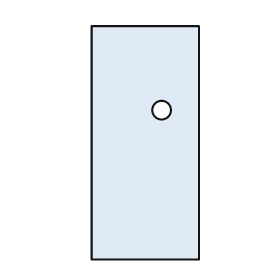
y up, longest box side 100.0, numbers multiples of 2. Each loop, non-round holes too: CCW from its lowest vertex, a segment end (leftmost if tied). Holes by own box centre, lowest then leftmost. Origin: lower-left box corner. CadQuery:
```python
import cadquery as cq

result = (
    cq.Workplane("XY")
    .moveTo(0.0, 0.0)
    .lineTo(46.0, 0.0)
    .lineTo(46.0, 100.0)
    .lineTo(0.0, 100.0)
    .close()
    .moveTo(30.0, 64.0)
    .circle(4.0)
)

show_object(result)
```